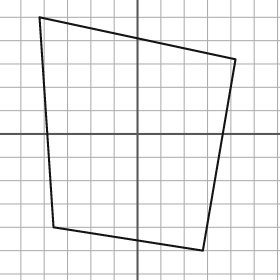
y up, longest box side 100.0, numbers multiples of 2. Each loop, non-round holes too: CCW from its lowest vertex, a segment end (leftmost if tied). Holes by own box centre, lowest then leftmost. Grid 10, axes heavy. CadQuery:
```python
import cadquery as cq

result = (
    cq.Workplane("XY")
    .moveTo(28.0, -50.0)
    .lineTo(42.0, 32.0)
    .lineTo(-42.0, 50.0)
    .lineTo(-36.0, -40.0)
    .close()
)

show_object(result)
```